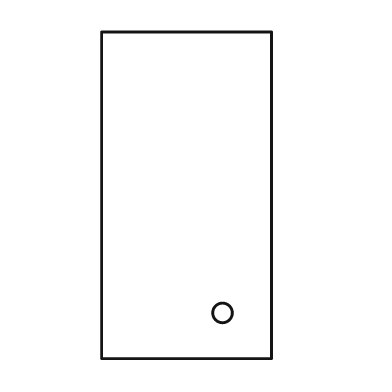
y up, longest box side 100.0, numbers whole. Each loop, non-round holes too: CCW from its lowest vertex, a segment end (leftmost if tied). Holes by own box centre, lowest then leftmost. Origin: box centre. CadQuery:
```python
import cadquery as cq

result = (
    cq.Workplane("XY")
    .moveTo(-26.0, -50.0)
    .lineTo(26.0, -50.0)
    .lineTo(26.0, 50.0)
    .lineTo(-26.0, 50.0)
    .close()
    .moveTo(11.0, -36.0)
    .circle(3.0)
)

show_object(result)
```